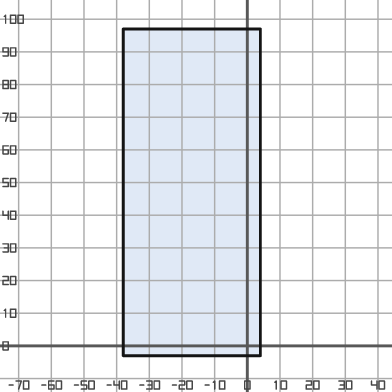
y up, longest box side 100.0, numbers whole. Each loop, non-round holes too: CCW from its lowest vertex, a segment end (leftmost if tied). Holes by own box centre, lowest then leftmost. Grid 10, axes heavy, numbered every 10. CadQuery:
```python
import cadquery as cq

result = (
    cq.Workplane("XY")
    .moveTo(-38.0, -3.0)
    .lineTo(4.0, -3.0)
    .lineTo(4.0, 97.0)
    .lineTo(-38.0, 97.0)
    .close()
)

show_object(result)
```